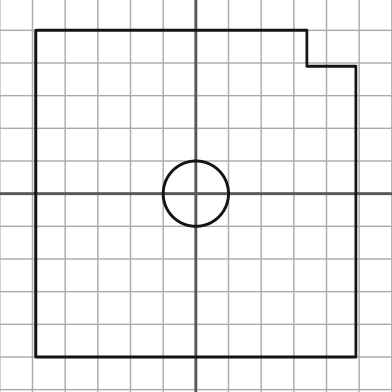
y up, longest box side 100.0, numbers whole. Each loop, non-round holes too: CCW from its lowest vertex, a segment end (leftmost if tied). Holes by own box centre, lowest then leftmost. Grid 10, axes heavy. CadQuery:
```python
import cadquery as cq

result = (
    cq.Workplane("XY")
    .moveTo(-49.0, -50.0)
    .lineTo(49.0, -50.0)
    .lineTo(49.0, 39.0)
    .lineTo(34.0, 39.0)
    .lineTo(34.0, 50.0)
    .lineTo(-49.0, 50.0)
    .close()
    .moveTo(0.0, 0.0)
    .circle(10.0)
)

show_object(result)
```